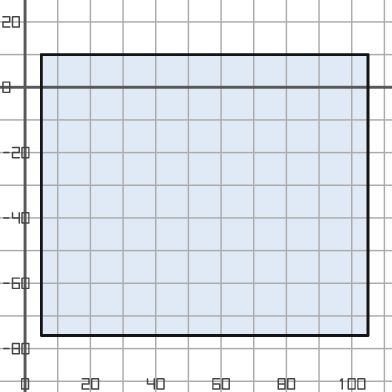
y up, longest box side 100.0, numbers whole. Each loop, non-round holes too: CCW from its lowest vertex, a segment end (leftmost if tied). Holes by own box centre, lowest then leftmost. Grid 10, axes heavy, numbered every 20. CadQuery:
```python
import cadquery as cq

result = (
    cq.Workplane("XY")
    .moveTo(5.0, -76.0)
    .lineTo(105.0, -76.0)
    .lineTo(105.0, 10.0)
    .lineTo(5.0, 10.0)
    .close()
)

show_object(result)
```